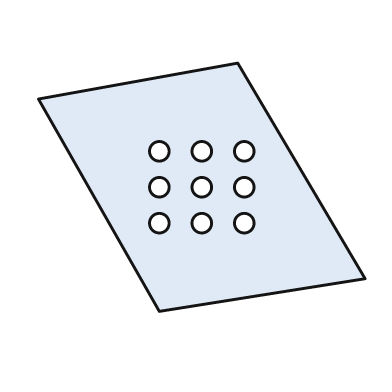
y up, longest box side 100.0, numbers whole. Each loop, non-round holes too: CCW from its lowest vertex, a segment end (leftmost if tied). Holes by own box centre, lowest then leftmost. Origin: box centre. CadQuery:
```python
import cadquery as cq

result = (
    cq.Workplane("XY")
    .moveTo(-13.0, -38.0)
    .lineTo(50.0, -28.0)
    .lineTo(11.0, 38.0)
    .lineTo(-50.0, 27.0)
    .close()
    .moveTo(-13.0, -11.0)
    .circle(3.0)
    .moveTo(0.0, -11.0)
    .circle(3.0)
    .moveTo(13.0, -11.0)
    .circle(3.0)
    .moveTo(-13.0, 0.0)
    .circle(3.0)
    .moveTo(0.0, 0.0)
    .circle(3.0)
    .moveTo(13.0, 0.0)
    .circle(3.0)
    .moveTo(-13.0, 11.0)
    .circle(3.0)
    .moveTo(0.0, 11.0)
    .circle(3.0)
    .moveTo(13.0, 11.0)
    .circle(3.0)
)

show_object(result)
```